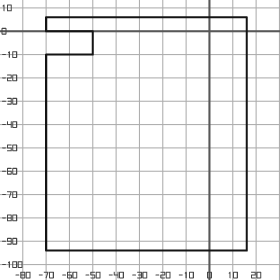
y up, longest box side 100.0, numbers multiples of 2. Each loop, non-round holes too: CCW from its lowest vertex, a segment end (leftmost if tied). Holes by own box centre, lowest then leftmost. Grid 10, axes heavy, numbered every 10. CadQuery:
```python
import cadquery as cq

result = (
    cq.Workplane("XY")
    .moveTo(-70.0, -94.0)
    .lineTo(16.0, -94.0)
    .lineTo(16.0, 6.0)
    .lineTo(-70.0, 6.0)
    .lineTo(-70.0, 0.0)
    .lineTo(-50.0, 0.0)
    .lineTo(-50.0, -10.0)
    .lineTo(-70.0, -10.0)
    .close()
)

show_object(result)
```